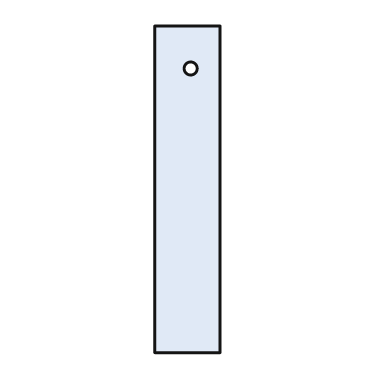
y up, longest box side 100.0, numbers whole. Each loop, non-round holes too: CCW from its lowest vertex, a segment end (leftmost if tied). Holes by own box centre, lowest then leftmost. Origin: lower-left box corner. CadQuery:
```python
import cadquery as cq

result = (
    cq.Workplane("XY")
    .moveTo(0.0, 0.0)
    .lineTo(20.0, 0.0)
    .lineTo(20.0, 100.0)
    .lineTo(0.0, 100.0)
    .close()
    .moveTo(11.0, 87.0)
    .circle(2.0)
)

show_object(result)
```